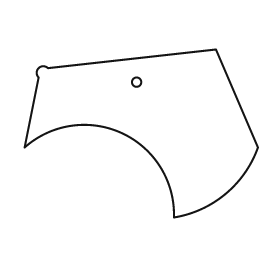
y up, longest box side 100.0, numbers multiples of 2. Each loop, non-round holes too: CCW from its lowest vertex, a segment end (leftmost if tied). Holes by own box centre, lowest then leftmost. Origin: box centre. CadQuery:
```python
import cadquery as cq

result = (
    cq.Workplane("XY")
    .moveTo(14.0, -36.0)
    .threePointArc((36.0, -26.0), (50.0, -6.0))
    .lineTo(32.0, 36.0)
    .lineTo(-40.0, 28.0)
    .threePointArc((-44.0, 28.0), (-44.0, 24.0))
    .lineTo(-50.0, -6.0)
    .threePointArc((-8.0, 0.0), (14.0, -36.0))
    .close()
    .moveTo(-2.0, 22.0)
    .circle(2.0)
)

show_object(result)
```